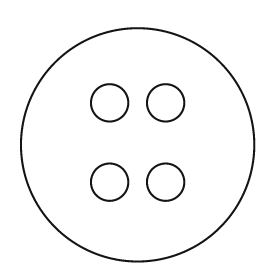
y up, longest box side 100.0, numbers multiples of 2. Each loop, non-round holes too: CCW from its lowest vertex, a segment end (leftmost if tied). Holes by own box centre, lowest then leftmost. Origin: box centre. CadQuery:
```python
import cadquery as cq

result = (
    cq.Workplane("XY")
    .moveTo(0.0, 0.0)
    .circle(50.0)
    .moveTo(-12.0, -16.0)
    .circle(8.0)
    .moveTo(12.0, -16.0)
    .circle(8.0)
    .moveTo(-12.0, 18.0)
    .circle(8.0)
    .moveTo(12.0, 18.0)
    .circle(8.0)
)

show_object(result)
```